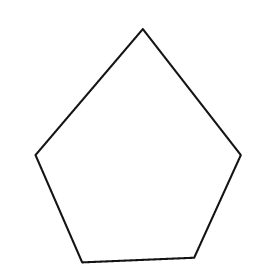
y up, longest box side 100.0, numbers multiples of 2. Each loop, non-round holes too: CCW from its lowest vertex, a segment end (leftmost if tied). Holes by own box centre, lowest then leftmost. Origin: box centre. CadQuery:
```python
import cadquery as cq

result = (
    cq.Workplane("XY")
    .moveTo(-24.0, -50.0)
    .lineTo(24.0, -48.0)
    .lineTo(44.0, -4.0)
    .lineTo(2.0, 50.0)
    .lineTo(-44.0, -4.0)
    .close()
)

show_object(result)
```